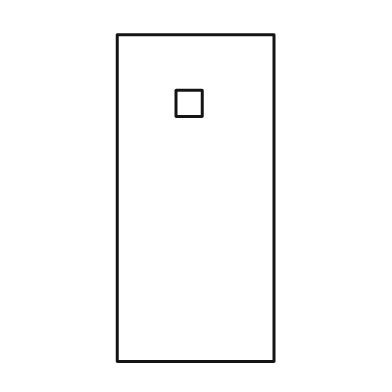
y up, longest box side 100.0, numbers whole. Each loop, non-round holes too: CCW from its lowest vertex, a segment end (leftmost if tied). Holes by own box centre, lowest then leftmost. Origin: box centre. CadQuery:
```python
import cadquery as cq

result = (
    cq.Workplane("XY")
    .moveTo(-24.0, -50.0)
    .lineTo(24.0, -50.0)
    .lineTo(24.0, 50.0)
    .lineTo(-24.0, 50.0)
    .close()
    .moveTo(-6.0, 25.0)
    .lineTo(2.0, 25.0)
    .lineTo(2.0, 33.0)
    .lineTo(-6.0, 33.0)
    .close()
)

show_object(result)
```